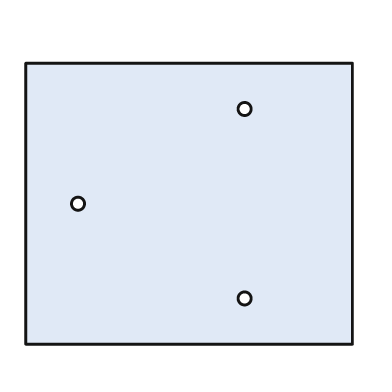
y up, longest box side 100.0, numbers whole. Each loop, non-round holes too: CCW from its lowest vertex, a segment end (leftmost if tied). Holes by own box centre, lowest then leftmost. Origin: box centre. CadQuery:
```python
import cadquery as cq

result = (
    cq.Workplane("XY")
    .moveTo(-50.0, -43.0)
    .lineTo(50.0, -43.0)
    .lineTo(50.0, 43.0)
    .lineTo(-50.0, 43.0)
    .close()
    .moveTo(17.0, -29.0)
    .circle(2.0)
    .moveTo(-34.0, 0.0)
    .circle(2.0)
    .moveTo(17.0, 29.0)
    .circle(2.0)
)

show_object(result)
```